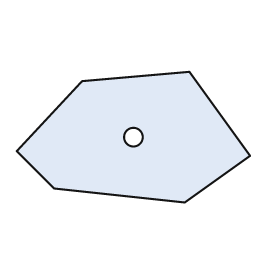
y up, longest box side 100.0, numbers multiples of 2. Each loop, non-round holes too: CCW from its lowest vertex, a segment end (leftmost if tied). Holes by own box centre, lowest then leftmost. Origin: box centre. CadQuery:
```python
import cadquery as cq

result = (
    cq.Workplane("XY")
    .moveTo(22.0, -28.0)
    .lineTo(50.0, -8.0)
    .lineTo(24.0, 28.0)
    .lineTo(-22.0, 24.0)
    .lineTo(-50.0, -6.0)
    .lineTo(-34.0, -22.0)
    .close()
    .moveTo(0.0, 0.0)
    .circle(4.0)
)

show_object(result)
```